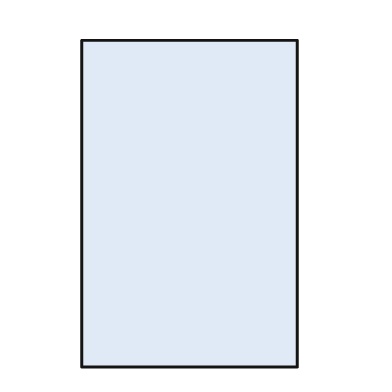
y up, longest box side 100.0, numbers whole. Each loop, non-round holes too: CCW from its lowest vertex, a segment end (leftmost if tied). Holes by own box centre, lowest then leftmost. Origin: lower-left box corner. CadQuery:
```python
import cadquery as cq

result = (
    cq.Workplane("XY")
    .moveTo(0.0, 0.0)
    .lineTo(66.0, 0.0)
    .lineTo(66.0, 100.0)
    .lineTo(0.0, 100.0)
    .close()
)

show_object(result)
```